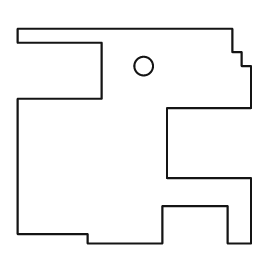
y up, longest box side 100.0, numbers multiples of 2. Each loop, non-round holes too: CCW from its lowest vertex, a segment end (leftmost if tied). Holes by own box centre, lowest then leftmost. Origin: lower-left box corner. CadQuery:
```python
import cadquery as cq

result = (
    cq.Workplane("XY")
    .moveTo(30.0, 0.0)
    .lineTo(62.0, 0.0)
    .lineTo(62.0, 16.0)
    .lineTo(90.0, 16.0)
    .lineTo(90.0, 0.0)
    .lineTo(100.0, 0.0)
    .lineTo(100.0, 28.0)
    .lineTo(64.0, 28.0)
    .lineTo(64.0, 58.0)
    .lineTo(100.0, 58.0)
    .lineTo(100.0, 76.0)
    .lineTo(96.0, 76.0)
    .lineTo(96.0, 82.0)
    .lineTo(92.0, 82.0)
    .lineTo(92.0, 92.0)
    .lineTo(0.0, 92.0)
    .lineTo(0.0, 86.0)
    .lineTo(36.0, 86.0)
    .lineTo(36.0, 62.0)
    .lineTo(0.0, 62.0)
    .lineTo(0.0, 4.0)
    .lineTo(30.0, 4.0)
    .close()
    .moveTo(54.0, 76.0)
    .circle(4.0)
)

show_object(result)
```